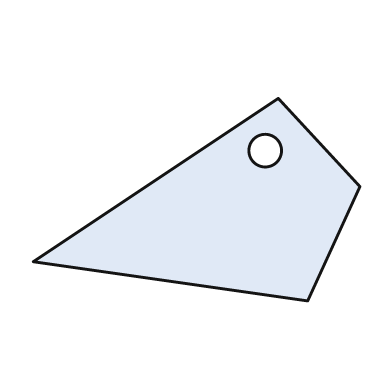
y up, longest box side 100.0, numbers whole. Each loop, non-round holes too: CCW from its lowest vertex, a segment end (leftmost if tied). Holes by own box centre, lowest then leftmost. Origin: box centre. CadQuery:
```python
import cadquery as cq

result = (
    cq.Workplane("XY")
    .moveTo(34.0, -31.0)
    .lineTo(50.0, 4.0)
    .lineTo(25.0, 31.0)
    .lineTo(-50.0, -19.0)
    .close()
    .moveTo(21.0, 15.0)
    .circle(5.0)
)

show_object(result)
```